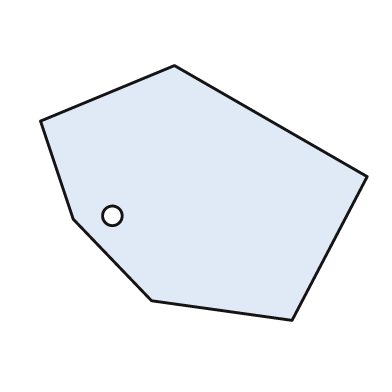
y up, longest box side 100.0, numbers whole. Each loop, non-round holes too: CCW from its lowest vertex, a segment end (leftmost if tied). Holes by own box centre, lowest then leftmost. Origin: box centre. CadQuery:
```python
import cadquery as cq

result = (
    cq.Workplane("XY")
    .moveTo(27.0, -39.0)
    .lineTo(50.0, 5.0)
    .lineTo(-9.0, 39.0)
    .lineTo(-50.0, 22.0)
    .lineTo(-40.0, -8.0)
    .lineTo(-16.0, -33.0)
    .close()
    .moveTo(-28.0, -7.0)
    .circle(3.0)
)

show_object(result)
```